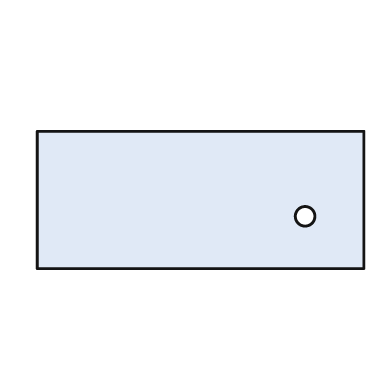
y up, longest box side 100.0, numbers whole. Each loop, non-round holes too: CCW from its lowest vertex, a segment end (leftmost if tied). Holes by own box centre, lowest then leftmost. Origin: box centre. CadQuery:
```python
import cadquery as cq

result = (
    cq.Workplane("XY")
    .moveTo(-50.0, -21.0)
    .lineTo(50.0, -21.0)
    .lineTo(50.0, 21.0)
    .lineTo(-50.0, 21.0)
    .close()
    .moveTo(32.0, -5.0)
    .circle(3.0)
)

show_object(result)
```